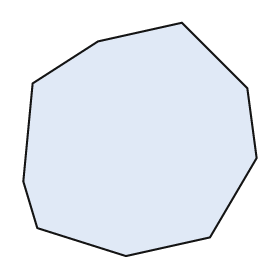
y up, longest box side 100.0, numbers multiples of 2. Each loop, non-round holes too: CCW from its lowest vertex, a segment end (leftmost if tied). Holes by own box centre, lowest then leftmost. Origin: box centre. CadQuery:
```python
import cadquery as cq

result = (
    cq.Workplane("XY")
    .moveTo(-6.0, -50.0)
    .lineTo(30.0, -42.0)
    .lineTo(50.0, -8.0)
    .lineTo(46.0, 22.0)
    .lineTo(18.0, 50.0)
    .lineTo(-18.0, 42.0)
    .lineTo(-46.0, 24.0)
    .lineTo(-50.0, -18.0)
    .lineTo(-44.0, -38.0)
    .close()
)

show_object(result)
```